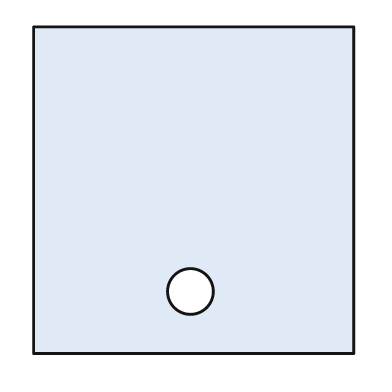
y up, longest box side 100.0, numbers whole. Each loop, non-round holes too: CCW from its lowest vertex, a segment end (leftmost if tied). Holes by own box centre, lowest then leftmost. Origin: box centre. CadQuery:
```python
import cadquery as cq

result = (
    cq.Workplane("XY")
    .moveTo(-49.0, -50.0)
    .lineTo(49.0, -50.0)
    .lineTo(49.0, 50.0)
    .lineTo(-49.0, 50.0)
    .close()
    .moveTo(-1.0, -31.0)
    .circle(7.0)
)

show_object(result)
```